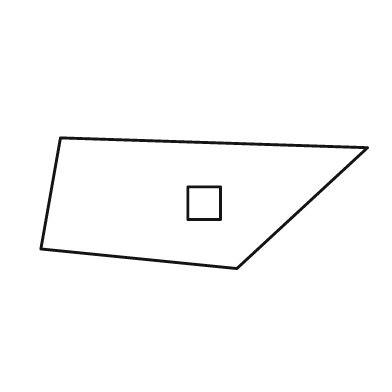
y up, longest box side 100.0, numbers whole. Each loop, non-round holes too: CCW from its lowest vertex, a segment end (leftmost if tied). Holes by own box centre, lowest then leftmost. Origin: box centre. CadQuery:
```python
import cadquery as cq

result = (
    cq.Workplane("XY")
    .moveTo(10.0, -20.0)
    .lineTo(50.0, 17.0)
    .lineTo(-44.0, 20.0)
    .lineTo(-50.0, -14.0)
    .close()
    .moveTo(-5.0, -5.0)
    .lineTo(5.0, -5.0)
    .lineTo(5.0, 5.0)
    .lineTo(-5.0, 5.0)
    .close()
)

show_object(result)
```